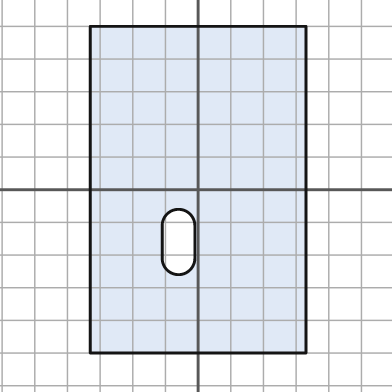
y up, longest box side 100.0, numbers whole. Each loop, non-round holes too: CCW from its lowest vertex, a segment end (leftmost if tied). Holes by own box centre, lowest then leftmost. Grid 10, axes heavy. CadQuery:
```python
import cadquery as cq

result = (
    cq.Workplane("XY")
    .moveTo(-33.0, -50.0)
    .lineTo(33.0, -50.0)
    .lineTo(33.0, 50.0)
    .lineTo(-33.0, 50.0)
    .close()
    .moveTo(-11.0, -21.0)
    .threePointArc((-6.0, -26.0), (-1.0, -21.0))
    .lineTo(-1.0, -11.0)
    .threePointArc((-6.0, -6.0), (-11.0, -11.0))
    .close()
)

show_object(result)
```